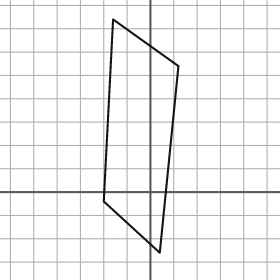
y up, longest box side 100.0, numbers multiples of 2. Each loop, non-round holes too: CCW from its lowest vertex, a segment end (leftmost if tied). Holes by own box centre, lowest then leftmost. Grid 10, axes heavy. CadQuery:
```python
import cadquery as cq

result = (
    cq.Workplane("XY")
    .moveTo(4.0, -26.0)
    .lineTo(12.0, 54.0)
    .lineTo(-16.0, 74.0)
    .lineTo(-20.0, -4.0)
    .close()
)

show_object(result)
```